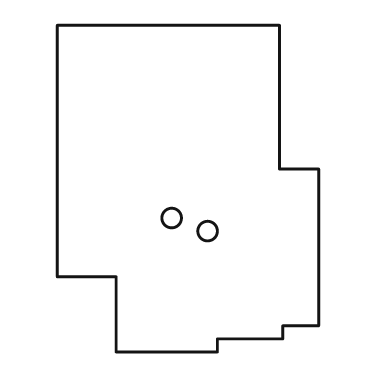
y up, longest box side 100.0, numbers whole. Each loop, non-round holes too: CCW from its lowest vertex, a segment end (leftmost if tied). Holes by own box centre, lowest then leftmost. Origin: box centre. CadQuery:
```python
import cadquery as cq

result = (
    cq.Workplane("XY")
    .moveTo(-22.0, -50.0)
    .lineTo(9.0, -50.0)
    .lineTo(9.0, -46.0)
    .lineTo(29.0, -46.0)
    .lineTo(29.0, -42.0)
    .lineTo(40.0, -42.0)
    .lineTo(40.0, 6.0)
    .lineTo(28.0, 6.0)
    .lineTo(28.0, 50.0)
    .lineTo(-40.0, 50.0)
    .lineTo(-40.0, -27.0)
    .lineTo(-22.0, -27.0)
    .close()
    .moveTo(6.0, -13.0)
    .circle(3.0)
    .moveTo(-5.0, -9.0)
    .circle(3.0)
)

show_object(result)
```